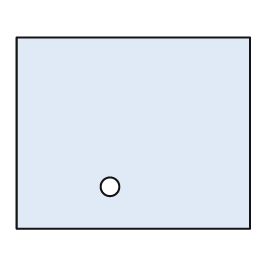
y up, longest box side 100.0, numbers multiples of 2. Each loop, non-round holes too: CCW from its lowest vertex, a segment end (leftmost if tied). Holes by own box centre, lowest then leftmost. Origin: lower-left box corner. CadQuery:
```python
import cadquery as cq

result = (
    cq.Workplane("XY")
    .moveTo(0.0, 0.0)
    .lineTo(100.0, 0.0)
    .lineTo(100.0, 82.0)
    .lineTo(0.0, 82.0)
    .close()
    .moveTo(40.0, 18.0)
    .circle(4.0)
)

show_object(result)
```